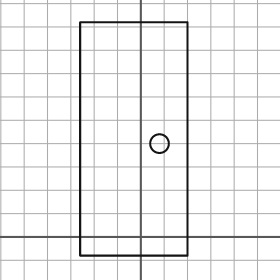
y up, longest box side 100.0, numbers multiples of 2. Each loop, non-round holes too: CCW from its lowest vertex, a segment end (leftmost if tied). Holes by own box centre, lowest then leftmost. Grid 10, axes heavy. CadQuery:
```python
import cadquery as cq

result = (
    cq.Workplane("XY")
    .moveTo(-26.0, -8.0)
    .lineTo(20.0, -8.0)
    .lineTo(20.0, 92.0)
    .lineTo(-26.0, 92.0)
    .close()
    .moveTo(8.0, 40.0)
    .circle(4.0)
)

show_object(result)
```